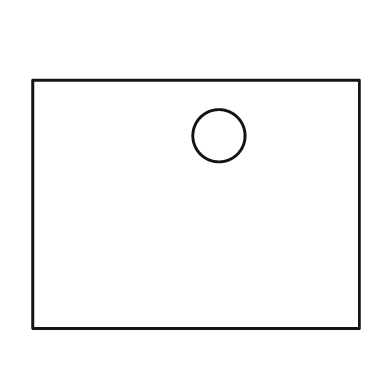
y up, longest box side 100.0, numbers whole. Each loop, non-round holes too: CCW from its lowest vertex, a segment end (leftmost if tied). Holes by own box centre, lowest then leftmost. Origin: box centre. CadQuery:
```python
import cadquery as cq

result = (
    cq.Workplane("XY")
    .moveTo(-50.0, -38.0)
    .lineTo(50.0, -38.0)
    .lineTo(50.0, 38.0)
    .lineTo(-50.0, 38.0)
    .close()
    .moveTo(7.0, 21.0)
    .circle(8.0)
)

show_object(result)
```